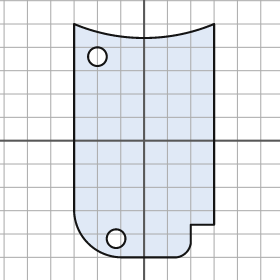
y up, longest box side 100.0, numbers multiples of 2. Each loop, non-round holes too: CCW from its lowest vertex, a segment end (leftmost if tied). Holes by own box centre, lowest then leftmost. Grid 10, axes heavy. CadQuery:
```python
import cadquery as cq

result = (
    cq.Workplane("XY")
    .moveTo(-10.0, -50.0)
    .lineTo(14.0, -50.0)
    .threePointArc((18.0, -48.0), (20.0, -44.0))
    .lineTo(20.0, -36.0)
    .lineTo(30.0, -36.0)
    .lineTo(30.0, 50.0)
    .threePointArc((0.0, 44.0), (-30.0, 50.0))
    .lineTo(-30.0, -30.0)
    .threePointArc((-24.0, -44.0), (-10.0, -50.0))
    .close()
    .moveTo(-12.0, -42.0)
    .circle(4.0)
    .moveTo(-20.0, 36.0)
    .circle(4.0)
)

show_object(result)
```